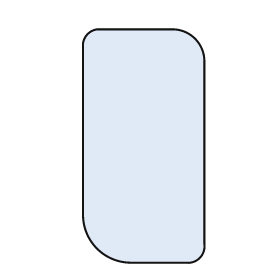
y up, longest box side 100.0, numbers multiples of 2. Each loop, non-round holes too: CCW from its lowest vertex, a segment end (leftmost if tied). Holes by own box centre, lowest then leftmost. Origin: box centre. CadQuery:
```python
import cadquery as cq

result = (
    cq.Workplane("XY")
    .moveTo(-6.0, -50.0)
    .lineTo(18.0, -50.0)
    .threePointArc((24.0, -48.0), (26.0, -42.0))
    .lineTo(26.0, 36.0)
    .threePointArc((22.0, 46.0), (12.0, 50.0))
    .lineTo(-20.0, 50.0)
    .threePointArc((-24.0, 48.0), (-26.0, 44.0))
    .lineTo(-26.0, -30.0)
    .threePointArc((-20.0, -44.0), (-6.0, -50.0))
    .close()
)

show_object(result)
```